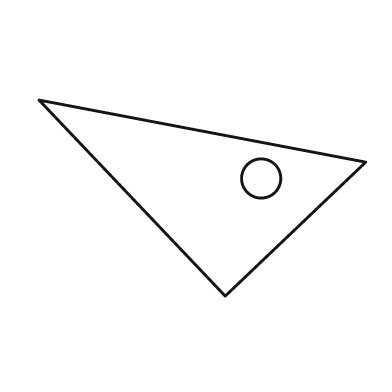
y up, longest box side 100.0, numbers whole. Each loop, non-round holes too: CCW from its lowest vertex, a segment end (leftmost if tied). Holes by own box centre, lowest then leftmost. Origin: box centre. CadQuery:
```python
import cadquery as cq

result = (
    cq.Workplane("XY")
    .moveTo(7.0, -30.0)
    .lineTo(50.0, 11.0)
    .lineTo(-50.0, 30.0)
    .close()
    .moveTo(18.0, 6.0)
    .circle(6.0)
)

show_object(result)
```